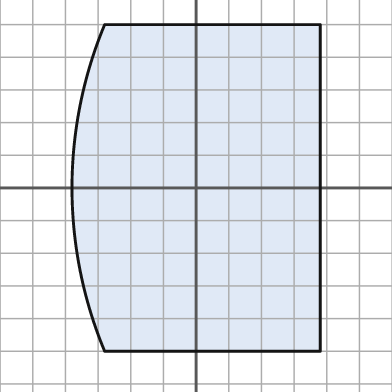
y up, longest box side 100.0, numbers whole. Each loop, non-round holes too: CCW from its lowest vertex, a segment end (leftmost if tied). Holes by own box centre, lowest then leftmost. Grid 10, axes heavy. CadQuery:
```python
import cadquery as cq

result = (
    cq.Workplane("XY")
    .moveTo(-28.0, -50.0)
    .lineTo(38.0, -50.0)
    .lineTo(38.0, 50.0)
    .lineTo(-28.0, 50.0)
    .threePointArc((-38.0, 0.0), (-28.0, -50.0))
    .close()
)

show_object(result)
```